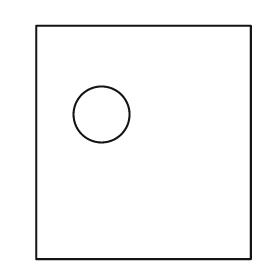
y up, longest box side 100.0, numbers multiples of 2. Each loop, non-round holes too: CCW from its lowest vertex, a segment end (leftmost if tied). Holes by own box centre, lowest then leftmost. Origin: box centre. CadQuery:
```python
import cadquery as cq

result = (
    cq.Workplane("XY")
    .moveTo(-46.0, -50.0)
    .lineTo(46.0, -50.0)
    .lineTo(46.0, 50.0)
    .lineTo(-46.0, 50.0)
    .close()
    .moveTo(-18.0, 12.0)
    .circle(12.0)
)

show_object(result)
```